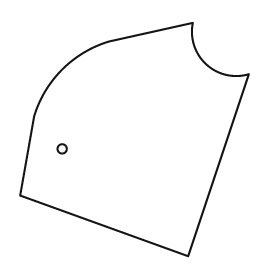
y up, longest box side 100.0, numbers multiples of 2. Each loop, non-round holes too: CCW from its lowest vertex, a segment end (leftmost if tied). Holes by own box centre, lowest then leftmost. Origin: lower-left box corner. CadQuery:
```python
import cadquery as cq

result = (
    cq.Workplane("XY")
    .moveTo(72.0, 0.0)
    .lineTo(98.0, 78.0)
    .threePointArc((80.0, 82.0), (74.0, 100.0))
    .lineTo(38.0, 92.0)
    .threePointArc((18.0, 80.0), (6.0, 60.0))
    .lineTo(0.0, 26.0)
    .close()
    .moveTo(18.0, 46.0)
    .circle(2.0)
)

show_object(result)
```